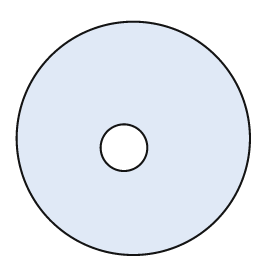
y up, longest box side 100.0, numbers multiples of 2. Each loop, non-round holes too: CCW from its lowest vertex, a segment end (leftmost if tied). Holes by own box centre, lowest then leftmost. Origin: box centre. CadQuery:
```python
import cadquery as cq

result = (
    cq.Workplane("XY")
    .moveTo(0.0, 0.0)
    .circle(50.0)
    .moveTo(-4.0, -4.0)
    .circle(10.0)
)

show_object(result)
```